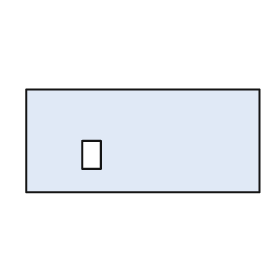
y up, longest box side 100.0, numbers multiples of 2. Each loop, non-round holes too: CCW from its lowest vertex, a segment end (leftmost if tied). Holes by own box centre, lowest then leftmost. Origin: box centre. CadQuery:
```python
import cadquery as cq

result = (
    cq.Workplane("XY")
    .moveTo(-50.0, -22.0)
    .lineTo(50.0, -22.0)
    .lineTo(50.0, 22.0)
    .lineTo(-50.0, 22.0)
    .close()
    .moveTo(-26.0, -12.0)
    .lineTo(-18.0, -12.0)
    .lineTo(-18.0, 0.0)
    .lineTo(-26.0, 0.0)
    .close()
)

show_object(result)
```